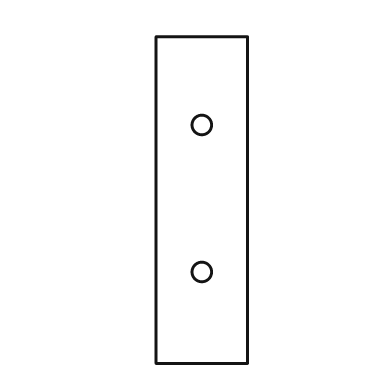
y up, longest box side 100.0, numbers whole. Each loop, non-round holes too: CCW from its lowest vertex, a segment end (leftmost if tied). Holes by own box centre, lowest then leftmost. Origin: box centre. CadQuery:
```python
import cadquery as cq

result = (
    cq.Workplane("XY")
    .moveTo(-14.0, -50.0)
    .lineTo(14.0, -50.0)
    .lineTo(14.0, 50.0)
    .lineTo(-14.0, 50.0)
    .close()
    .moveTo(0.0, -22.0)
    .circle(3.0)
    .moveTo(0.0, 23.0)
    .circle(3.0)
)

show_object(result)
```